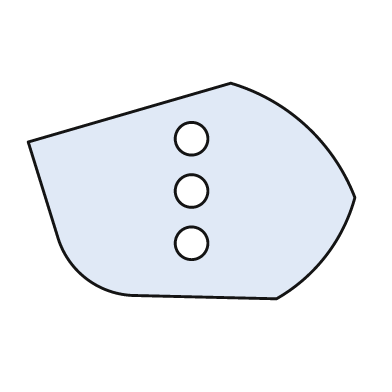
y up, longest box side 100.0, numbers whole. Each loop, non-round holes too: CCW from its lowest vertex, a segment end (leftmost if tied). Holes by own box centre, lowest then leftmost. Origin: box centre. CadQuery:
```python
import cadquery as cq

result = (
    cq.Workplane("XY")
    .moveTo(26.0, -33.0)
    .threePointArc((41.0, -20.0), (50.0, -2.0))
    .threePointArc((35.0, 20.0), (12.0, 33.0))
    .lineTo(-50.0, 15.0)
    .lineTo(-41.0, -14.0)
    .threePointArc((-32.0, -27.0), (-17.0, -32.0))
    .close()
    .moveTo(0.0, -16.0)
    .circle(5.0)
    .moveTo(0.0, 0.0)
    .circle(5.0)
    .moveTo(0.0, 16.0)
    .circle(5.0)
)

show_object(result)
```